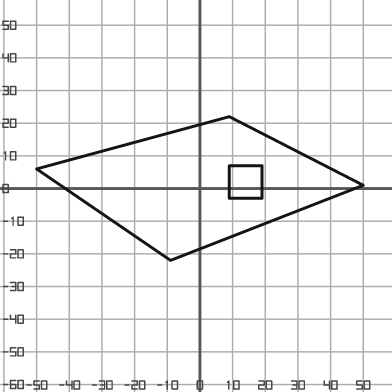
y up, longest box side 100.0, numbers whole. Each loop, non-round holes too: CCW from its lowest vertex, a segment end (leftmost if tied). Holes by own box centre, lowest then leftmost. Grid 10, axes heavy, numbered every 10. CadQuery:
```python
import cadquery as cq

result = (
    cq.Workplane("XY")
    .moveTo(-9.0, -22.0)
    .lineTo(50.0, 1.0)
    .lineTo(9.0, 22.0)
    .lineTo(-50.0, 6.0)
    .close()
    .moveTo(9.0, -3.0)
    .lineTo(19.0, -3.0)
    .lineTo(19.0, 7.0)
    .lineTo(9.0, 7.0)
    .close()
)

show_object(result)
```